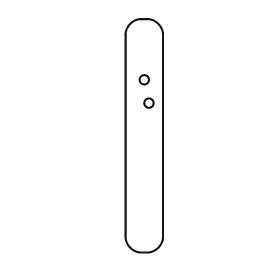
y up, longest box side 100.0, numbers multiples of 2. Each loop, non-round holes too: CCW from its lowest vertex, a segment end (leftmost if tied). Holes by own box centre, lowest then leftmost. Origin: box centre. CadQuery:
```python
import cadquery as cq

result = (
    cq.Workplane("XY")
    .moveTo(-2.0, -50.0)
    .lineTo(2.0, -50.0)
    .threePointArc((6.0, -48.0), (8.0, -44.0))
    .lineTo(8.0, 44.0)
    .threePointArc((6.0, 48.0), (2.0, 50.0))
    .lineTo(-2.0, 50.0)
    .threePointArc((-6.0, 48.0), (-8.0, 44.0))
    .lineTo(-8.0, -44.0)
    .threePointArc((-6.0, -48.0), (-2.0, -50.0))
    .close()
    .moveTo(2.0, 14.0)
    .circle(2.0)
    .moveTo(0.0, 24.0)
    .circle(2.0)
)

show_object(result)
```